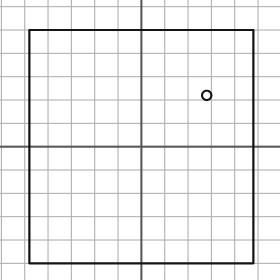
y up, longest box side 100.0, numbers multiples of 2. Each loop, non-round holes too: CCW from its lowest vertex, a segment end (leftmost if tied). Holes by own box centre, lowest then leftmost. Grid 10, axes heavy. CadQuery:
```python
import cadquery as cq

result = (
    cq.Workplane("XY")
    .moveTo(-48.0, -50.0)
    .lineTo(48.0, -50.0)
    .lineTo(48.0, 50.0)
    .lineTo(-48.0, 50.0)
    .close()
    .moveTo(28.0, 22.0)
    .circle(2.0)
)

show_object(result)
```